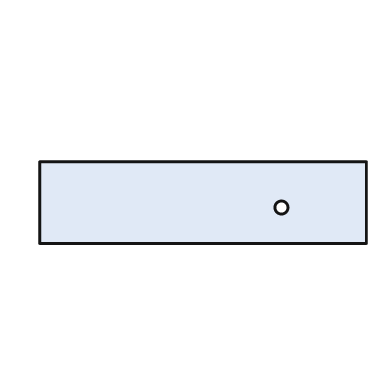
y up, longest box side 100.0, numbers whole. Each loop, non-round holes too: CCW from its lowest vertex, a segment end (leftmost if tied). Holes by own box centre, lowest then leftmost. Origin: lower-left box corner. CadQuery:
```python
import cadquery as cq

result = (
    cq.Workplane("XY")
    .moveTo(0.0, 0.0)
    .lineTo(100.0, 0.0)
    .lineTo(100.0, 25.0)
    .lineTo(0.0, 25.0)
    .close()
    .moveTo(74.0, 11.0)
    .circle(2.0)
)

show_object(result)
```